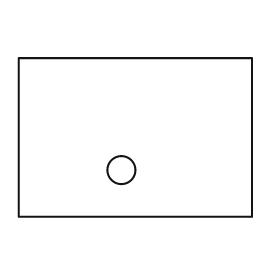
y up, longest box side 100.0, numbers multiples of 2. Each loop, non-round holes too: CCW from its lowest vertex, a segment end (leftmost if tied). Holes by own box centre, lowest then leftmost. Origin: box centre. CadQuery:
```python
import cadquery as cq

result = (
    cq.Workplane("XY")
    .moveTo(-50.0, -34.0)
    .lineTo(50.0, -34.0)
    .lineTo(50.0, 34.0)
    .lineTo(-50.0, 34.0)
    .close()
    .moveTo(-6.0, -14.0)
    .circle(6.0)
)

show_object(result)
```